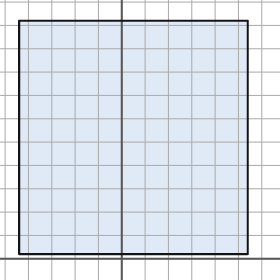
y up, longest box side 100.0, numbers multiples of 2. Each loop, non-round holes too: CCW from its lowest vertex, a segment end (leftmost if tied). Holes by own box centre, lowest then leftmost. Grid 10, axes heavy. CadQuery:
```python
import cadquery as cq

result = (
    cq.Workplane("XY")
    .moveTo(-44.0, 2.0)
    .lineTo(54.0, 2.0)
    .lineTo(54.0, 102.0)
    .lineTo(-44.0, 102.0)
    .close()
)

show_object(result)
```